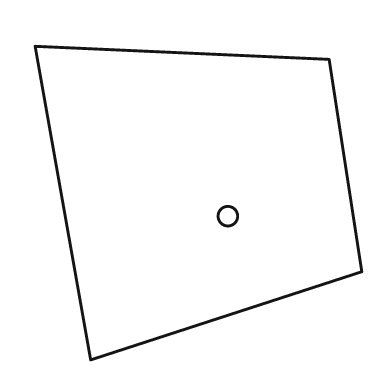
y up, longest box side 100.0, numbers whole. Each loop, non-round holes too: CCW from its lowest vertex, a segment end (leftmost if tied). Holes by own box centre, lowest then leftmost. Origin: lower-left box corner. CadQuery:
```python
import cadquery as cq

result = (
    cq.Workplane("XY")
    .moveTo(17.0, 0.0)
    .lineTo(100.0, 27.0)
    .lineTo(90.0, 92.0)
    .lineTo(0.0, 96.0)
    .close()
    .moveTo(59.0, 44.0)
    .circle(3.0)
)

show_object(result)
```